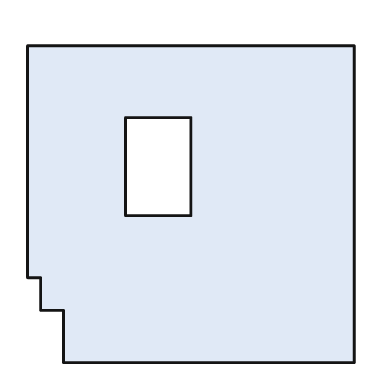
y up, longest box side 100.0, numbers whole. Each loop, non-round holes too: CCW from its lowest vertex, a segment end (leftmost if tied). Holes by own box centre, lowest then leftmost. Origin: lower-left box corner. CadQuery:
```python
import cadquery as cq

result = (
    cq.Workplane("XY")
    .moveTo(11.0, 0.0)
    .lineTo(100.0, 0.0)
    .lineTo(100.0, 97.0)
    .lineTo(0.0, 97.0)
    .lineTo(0.0, 26.0)
    .lineTo(4.0, 26.0)
    .lineTo(4.0, 16.0)
    .lineTo(11.0, 16.0)
    .close()
    .moveTo(30.0, 45.0)
    .lineTo(50.0, 45.0)
    .lineTo(50.0, 75.0)
    .lineTo(30.0, 75.0)
    .close()
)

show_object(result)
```